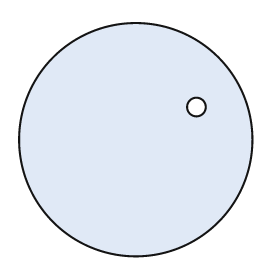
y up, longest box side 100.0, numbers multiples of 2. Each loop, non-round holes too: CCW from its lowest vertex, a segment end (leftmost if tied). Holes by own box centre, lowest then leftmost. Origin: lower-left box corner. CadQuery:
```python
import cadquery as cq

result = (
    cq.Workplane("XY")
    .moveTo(50.0, 50.0)
    .circle(50.0)
    .moveTo(76.0, 64.0)
    .circle(4.0)
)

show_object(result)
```